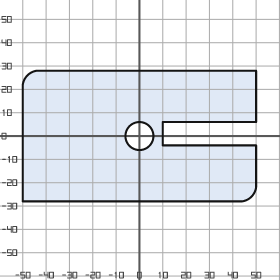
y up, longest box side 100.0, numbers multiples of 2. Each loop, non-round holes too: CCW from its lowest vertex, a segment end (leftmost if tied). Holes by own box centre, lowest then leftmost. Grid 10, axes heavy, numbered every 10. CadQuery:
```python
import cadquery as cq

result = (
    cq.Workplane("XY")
    .moveTo(-50.0, -28.0)
    .lineTo(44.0, -28.0)
    .threePointArc((48.0, -26.0), (50.0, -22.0))
    .lineTo(50.0, -4.0)
    .lineTo(10.0, -4.0)
    .lineTo(10.0, 6.0)
    .lineTo(50.0, 6.0)
    .lineTo(50.0, 28.0)
    .lineTo(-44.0, 28.0)
    .threePointArc((-48.0, 26.0), (-50.0, 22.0))
    .close()
    .moveTo(0.0, 0.0)
    .circle(6.0)
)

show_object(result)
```